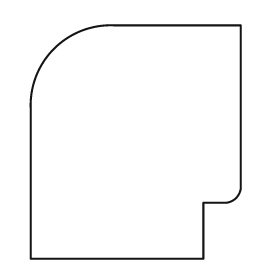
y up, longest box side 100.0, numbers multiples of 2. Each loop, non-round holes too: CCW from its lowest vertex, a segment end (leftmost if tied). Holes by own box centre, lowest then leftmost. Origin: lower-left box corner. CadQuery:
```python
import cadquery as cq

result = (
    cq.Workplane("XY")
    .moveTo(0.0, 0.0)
    .lineTo(74.0, 0.0)
    .lineTo(74.0, 24.0)
    .lineTo(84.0, 24.0)
    .threePointArc((88.0, 26.0), (90.0, 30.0))
    .lineTo(90.0, 100.0)
    .lineTo(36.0, 100.0)
    .threePointArc((10.0, 90.0), (0.0, 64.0))
    .close()
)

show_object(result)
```